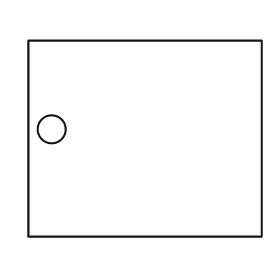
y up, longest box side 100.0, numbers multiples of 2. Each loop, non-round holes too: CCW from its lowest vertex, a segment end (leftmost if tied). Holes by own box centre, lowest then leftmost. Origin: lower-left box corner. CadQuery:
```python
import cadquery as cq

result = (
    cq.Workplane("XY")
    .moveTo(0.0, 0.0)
    .lineTo(100.0, 0.0)
    .lineTo(100.0, 84.0)
    .lineTo(0.0, 84.0)
    .close()
    .moveTo(10.0, 46.0)
    .circle(6.0)
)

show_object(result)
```